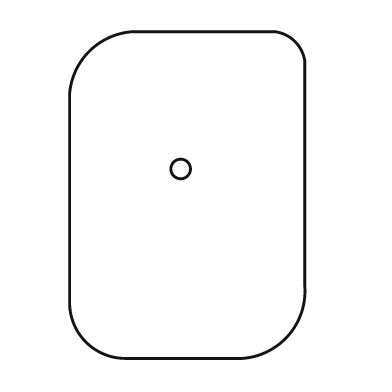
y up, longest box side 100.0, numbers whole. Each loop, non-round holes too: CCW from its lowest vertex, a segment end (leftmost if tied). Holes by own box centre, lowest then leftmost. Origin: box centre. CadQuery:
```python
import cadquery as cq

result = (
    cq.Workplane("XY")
    .moveTo(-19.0, -50.0)
    .lineTo(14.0, -50.0)
    .threePointArc((30.0, -44.0), (36.0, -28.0))
    .lineTo(36.0, 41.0)
    .threePointArc((33.0, 47.0), (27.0, 50.0))
    .lineTo(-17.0, 50.0)
    .threePointArc((-30.0, 44.0), (-36.0, 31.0))
    .lineTo(-36.0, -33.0)
    .threePointArc((-31.0, -45.0), (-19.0, -50.0))
    .close()
    .moveTo(-2.0, 8.0)
    .circle(3.0)
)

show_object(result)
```